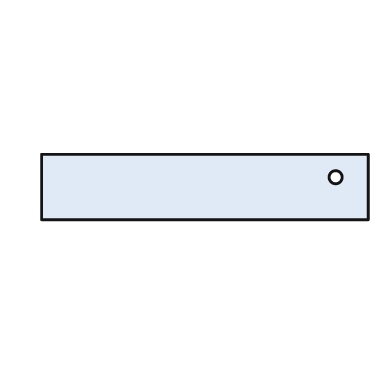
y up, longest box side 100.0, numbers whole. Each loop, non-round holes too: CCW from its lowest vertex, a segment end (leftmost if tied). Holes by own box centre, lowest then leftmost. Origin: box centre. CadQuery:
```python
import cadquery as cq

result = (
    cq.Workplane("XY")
    .moveTo(-50.0, -10.0)
    .lineTo(50.0, -10.0)
    .lineTo(50.0, 10.0)
    .lineTo(-50.0, 10.0)
    .close()
    .moveTo(40.0, 3.0)
    .circle(2.0)
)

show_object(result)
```